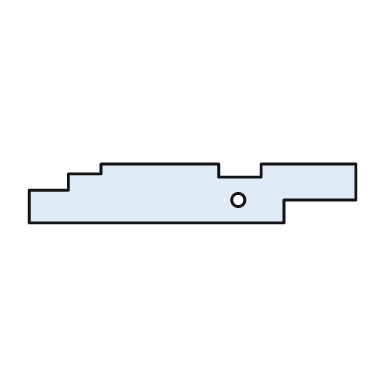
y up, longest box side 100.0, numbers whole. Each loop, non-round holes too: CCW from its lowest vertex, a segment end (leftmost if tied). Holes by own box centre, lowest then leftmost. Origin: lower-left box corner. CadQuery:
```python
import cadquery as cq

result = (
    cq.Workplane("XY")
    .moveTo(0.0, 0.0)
    .lineTo(78.0, 0.0)
    .lineTo(78.0, 7.0)
    .lineTo(100.0, 7.0)
    .lineTo(100.0, 18.0)
    .lineTo(71.0, 18.0)
    .lineTo(71.0, 14.0)
    .lineTo(58.0, 14.0)
    .lineTo(58.0, 18.0)
    .lineTo(22.0, 18.0)
    .lineTo(22.0, 15.0)
    .lineTo(12.0, 15.0)
    .lineTo(12.0, 10.0)
    .lineTo(0.0, 10.0)
    .close()
    .moveTo(64.0, 7.0)
    .circle(2.0)
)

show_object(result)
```